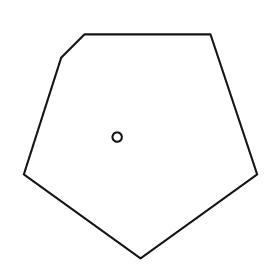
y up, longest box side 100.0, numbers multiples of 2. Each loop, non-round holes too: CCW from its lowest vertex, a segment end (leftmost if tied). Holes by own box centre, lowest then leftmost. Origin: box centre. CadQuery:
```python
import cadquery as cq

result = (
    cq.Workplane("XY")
    .moveTo(0.0, -48.0)
    .lineTo(50.0, -12.0)
    .lineTo(30.0, 48.0)
    .lineTo(-24.0, 48.0)
    .lineTo(-34.0, 38.0)
    .lineTo(-50.0, -12.0)
    .close()
    .moveTo(-10.0, 4.0)
    .circle(2.0)
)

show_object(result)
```